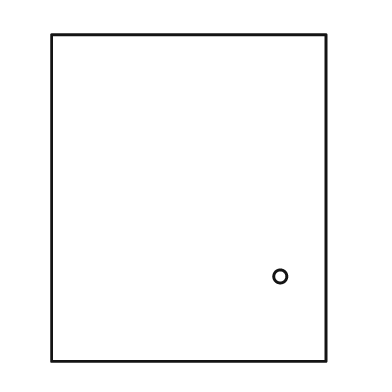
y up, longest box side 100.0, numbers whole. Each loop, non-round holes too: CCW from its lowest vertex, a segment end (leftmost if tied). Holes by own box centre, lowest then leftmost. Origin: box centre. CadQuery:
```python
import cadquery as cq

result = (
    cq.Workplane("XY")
    .moveTo(-42.0, -50.0)
    .lineTo(42.0, -50.0)
    .lineTo(42.0, 50.0)
    .lineTo(-42.0, 50.0)
    .close()
    .moveTo(28.0, -24.0)
    .circle(2.0)
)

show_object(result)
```